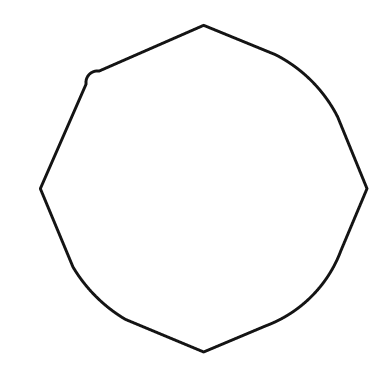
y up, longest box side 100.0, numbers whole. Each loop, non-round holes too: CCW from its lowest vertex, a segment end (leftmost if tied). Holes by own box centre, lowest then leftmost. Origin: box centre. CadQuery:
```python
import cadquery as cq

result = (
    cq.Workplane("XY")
    .moveTo(0.0, -50.0)
    .lineTo(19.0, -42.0)
    .threePointArc((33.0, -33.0), (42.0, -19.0))
    .lineTo(50.0, 0.0)
    .lineTo(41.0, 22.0)
    .threePointArc((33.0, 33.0), (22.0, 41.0))
    .lineTo(0.0, 50.0)
    .lineTo(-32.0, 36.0)
    .threePointArc((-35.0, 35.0), (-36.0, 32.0))
    .lineTo(-50.0, 0.0)
    .lineTo(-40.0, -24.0)
    .threePointArc((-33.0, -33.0), (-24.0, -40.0))
    .close()
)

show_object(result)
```